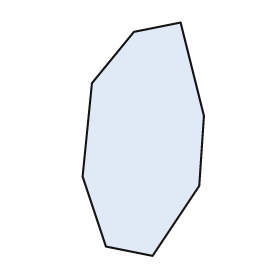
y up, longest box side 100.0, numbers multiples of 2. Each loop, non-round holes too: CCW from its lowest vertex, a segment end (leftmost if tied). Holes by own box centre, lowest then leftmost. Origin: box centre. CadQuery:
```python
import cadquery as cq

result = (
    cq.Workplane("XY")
    .moveTo(4.0, -50.0)
    .lineTo(24.0, -20.0)
    .lineTo(26.0, 10.0)
    .lineTo(16.0, 50.0)
    .lineTo(-4.0, 46.0)
    .lineTo(-22.0, 24.0)
    .lineTo(-26.0, -16.0)
    .lineTo(-16.0, -46.0)
    .close()
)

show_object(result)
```